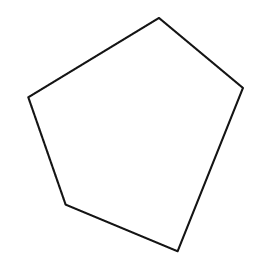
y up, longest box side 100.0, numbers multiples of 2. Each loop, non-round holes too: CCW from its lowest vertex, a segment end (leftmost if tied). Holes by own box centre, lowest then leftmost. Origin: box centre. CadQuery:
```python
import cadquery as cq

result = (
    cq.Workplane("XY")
    .moveTo(18.0, -50.0)
    .lineTo(46.0, 20.0)
    .lineTo(10.0, 50.0)
    .lineTo(-46.0, 16.0)
    .lineTo(-30.0, -30.0)
    .close()
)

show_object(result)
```